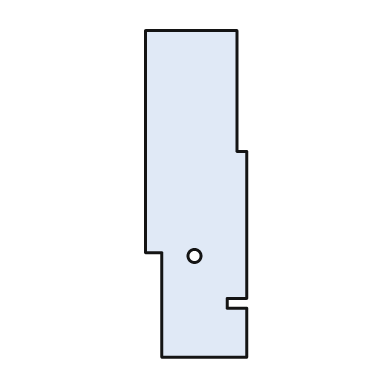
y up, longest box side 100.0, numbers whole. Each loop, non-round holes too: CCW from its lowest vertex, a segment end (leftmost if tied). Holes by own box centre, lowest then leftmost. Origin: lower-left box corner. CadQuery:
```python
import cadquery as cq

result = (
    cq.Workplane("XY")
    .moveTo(5.0, 0.0)
    .lineTo(31.0, 0.0)
    .lineTo(31.0, 15.0)
    .lineTo(25.0, 15.0)
    .lineTo(25.0, 18.0)
    .lineTo(31.0, 18.0)
    .lineTo(31.0, 63.0)
    .lineTo(28.0, 63.0)
    .lineTo(28.0, 100.0)
    .lineTo(0.0, 100.0)
    .lineTo(0.0, 32.0)
    .lineTo(5.0, 32.0)
    .close()
    .moveTo(15.0, 31.0)
    .circle(2.0)
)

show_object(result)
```